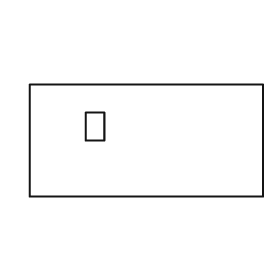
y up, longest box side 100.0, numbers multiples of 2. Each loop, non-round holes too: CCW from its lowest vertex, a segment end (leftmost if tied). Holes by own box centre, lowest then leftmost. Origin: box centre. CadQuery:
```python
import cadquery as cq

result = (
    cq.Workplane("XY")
    .moveTo(-50.0, -24.0)
    .lineTo(50.0, -24.0)
    .lineTo(50.0, 24.0)
    .lineTo(-50.0, 24.0)
    .close()
    .moveTo(-26.0, 0.0)
    .lineTo(-18.0, 0.0)
    .lineTo(-18.0, 12.0)
    .lineTo(-26.0, 12.0)
    .close()
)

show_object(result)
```